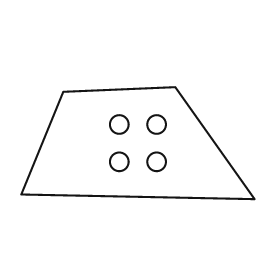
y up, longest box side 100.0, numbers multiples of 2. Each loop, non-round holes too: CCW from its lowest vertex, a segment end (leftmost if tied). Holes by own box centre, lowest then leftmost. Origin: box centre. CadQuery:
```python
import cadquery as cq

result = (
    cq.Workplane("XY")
    .moveTo(50.0, -24.0)
    .lineTo(16.0, 24.0)
    .lineTo(-32.0, 22.0)
    .lineTo(-50.0, -22.0)
    .close()
    .moveTo(-8.0, -8.0)
    .circle(4.0)
    .moveTo(8.0, -8.0)
    .circle(4.0)
    .moveTo(-8.0, 8.0)
    .circle(4.0)
    .moveTo(8.0, 8.0)
    .circle(4.0)
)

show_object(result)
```